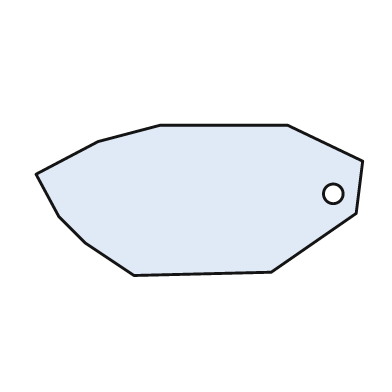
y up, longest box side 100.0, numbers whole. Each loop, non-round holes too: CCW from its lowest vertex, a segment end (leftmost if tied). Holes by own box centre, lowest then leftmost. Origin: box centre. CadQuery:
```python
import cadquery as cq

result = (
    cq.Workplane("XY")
    .moveTo(-20.0, -23.0)
    .lineTo(22.0, -22.0)
    .lineTo(48.0, -4.0)
    .lineTo(50.0, 12.0)
    .lineTo(27.0, 23.0)
    .lineTo(-12.0, 23.0)
    .lineTo(-31.0, 18.0)
    .lineTo(-50.0, 8.0)
    .lineTo(-43.0, -5.0)
    .lineTo(-35.0, -13.0)
    .close()
    .moveTo(41.0, 2.0)
    .circle(3.0)
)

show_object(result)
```